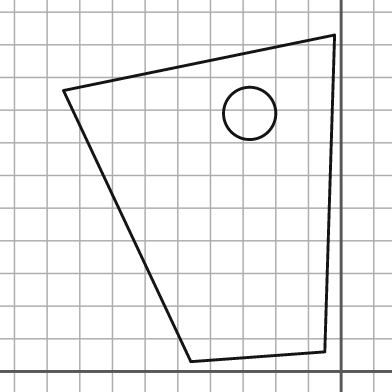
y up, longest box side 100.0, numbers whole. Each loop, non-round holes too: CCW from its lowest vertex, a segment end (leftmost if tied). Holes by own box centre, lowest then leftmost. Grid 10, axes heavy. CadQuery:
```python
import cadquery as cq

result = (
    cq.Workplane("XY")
    .moveTo(-46.0, 3.0)
    .lineTo(-5.0, 6.0)
    .lineTo(-2.0, 103.0)
    .lineTo(-85.0, 86.0)
    .close()
    .moveTo(-28.0, 79.0)
    .circle(8.0)
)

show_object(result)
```